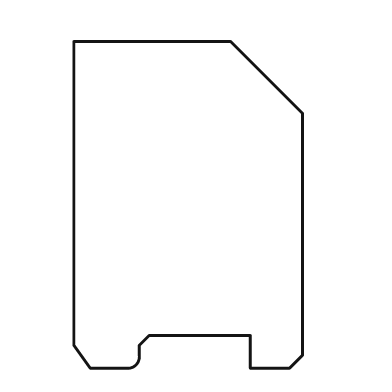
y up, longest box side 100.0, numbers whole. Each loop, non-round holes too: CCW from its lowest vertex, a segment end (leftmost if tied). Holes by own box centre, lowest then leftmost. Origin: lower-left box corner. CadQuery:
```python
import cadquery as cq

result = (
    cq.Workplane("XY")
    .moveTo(5.0, 0.0)
    .lineTo(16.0, 0.0)
    .threePointArc((19.0, 1.0), (20.0, 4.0))
    .lineTo(20.0, 7.0)
    .lineTo(23.0, 10.0)
    .lineTo(54.0, 10.0)
    .lineTo(54.0, 0.0)
    .lineTo(66.0, 0.0)
    .lineTo(70.0, 4.0)
    .lineTo(70.0, 78.0)
    .lineTo(48.0, 100.0)
    .lineTo(0.0, 100.0)
    .lineTo(0.0, 7.0)
    .close()
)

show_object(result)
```